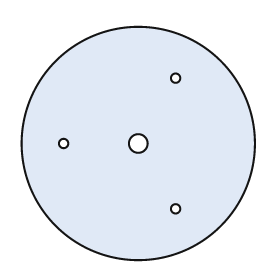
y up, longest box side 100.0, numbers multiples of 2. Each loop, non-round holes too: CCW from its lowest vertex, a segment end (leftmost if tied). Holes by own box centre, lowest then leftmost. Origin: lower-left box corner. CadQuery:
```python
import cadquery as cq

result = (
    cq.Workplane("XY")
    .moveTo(50.0, 50.0)
    .circle(50.0)
    .moveTo(66.0, 22.0)
    .circle(2.0)
    .moveTo(18.0, 50.0)
    .circle(2.0)
    .moveTo(50.0, 50.0)
    .circle(4.0)
    .moveTo(66.0, 78.0)
    .circle(2.0)
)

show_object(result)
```